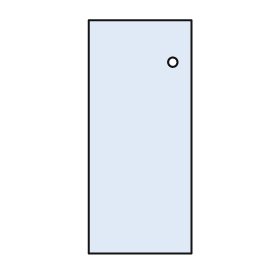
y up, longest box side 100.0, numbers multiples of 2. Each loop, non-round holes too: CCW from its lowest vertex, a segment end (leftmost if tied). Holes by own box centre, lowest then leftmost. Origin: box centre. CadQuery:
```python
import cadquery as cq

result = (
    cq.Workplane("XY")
    .moveTo(-22.0, -50.0)
    .lineTo(22.0, -50.0)
    .lineTo(22.0, 50.0)
    .lineTo(-22.0, 50.0)
    .close()
    .moveTo(14.0, 32.0)
    .circle(2.0)
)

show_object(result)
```